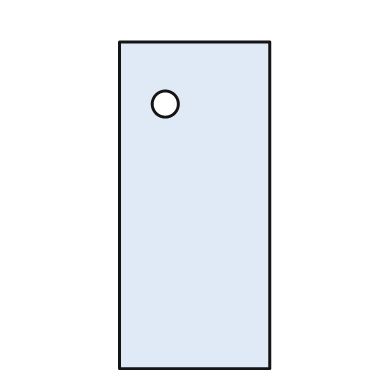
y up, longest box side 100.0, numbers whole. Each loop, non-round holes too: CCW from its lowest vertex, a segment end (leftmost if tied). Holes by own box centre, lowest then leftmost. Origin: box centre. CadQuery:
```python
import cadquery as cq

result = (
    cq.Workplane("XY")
    .moveTo(-23.0, -50.0)
    .lineTo(23.0, -50.0)
    .lineTo(23.0, 50.0)
    .lineTo(-23.0, 50.0)
    .close()
    .moveTo(-9.0, 31.0)
    .circle(4.0)
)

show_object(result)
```